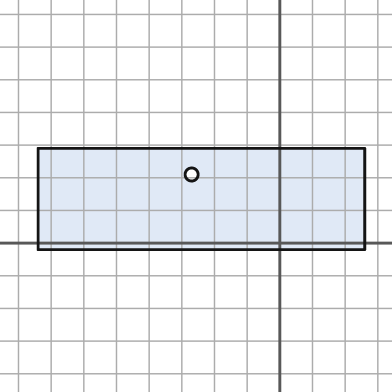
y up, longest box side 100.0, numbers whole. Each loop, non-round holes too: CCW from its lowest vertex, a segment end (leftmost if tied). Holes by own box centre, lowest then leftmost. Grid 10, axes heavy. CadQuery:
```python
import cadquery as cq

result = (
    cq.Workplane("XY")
    .moveTo(-74.0, -2.0)
    .lineTo(26.0, -2.0)
    .lineTo(26.0, 29.0)
    .lineTo(-74.0, 29.0)
    .close()
    .moveTo(-27.0, 21.0)
    .circle(2.0)
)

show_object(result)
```